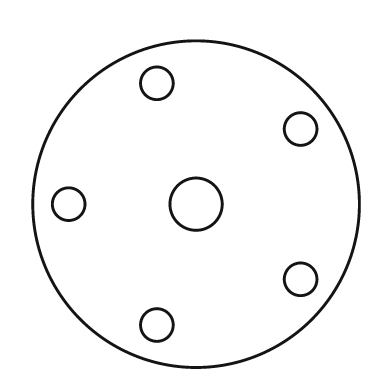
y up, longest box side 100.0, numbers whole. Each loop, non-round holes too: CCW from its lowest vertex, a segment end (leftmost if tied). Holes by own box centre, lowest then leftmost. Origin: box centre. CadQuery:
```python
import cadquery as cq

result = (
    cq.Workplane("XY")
    .moveTo(0.0, 0.0)
    .circle(50.0)
    .moveTo(-12.0, -37.0)
    .circle(5.0)
    .moveTo(32.0, -23.0)
    .circle(5.0)
    .moveTo(-39.0, 0.0)
    .circle(5.0)
    .moveTo(0.0, 0.0)
    .circle(8.0)
    .moveTo(32.0, 23.0)
    .circle(5.0)
    .moveTo(-12.0, 37.0)
    .circle(5.0)
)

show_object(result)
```